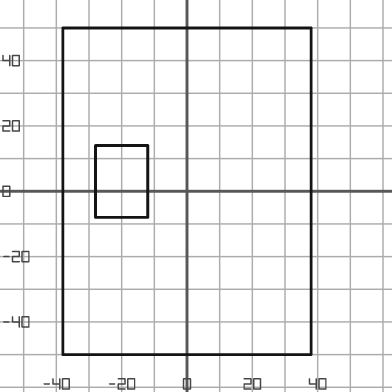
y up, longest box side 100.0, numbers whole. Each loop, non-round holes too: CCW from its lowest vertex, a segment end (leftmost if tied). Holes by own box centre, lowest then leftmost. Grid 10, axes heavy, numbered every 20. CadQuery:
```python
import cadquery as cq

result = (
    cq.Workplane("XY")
    .moveTo(-38.0, -50.0)
    .lineTo(38.0, -50.0)
    .lineTo(38.0, 50.0)
    .lineTo(-38.0, 50.0)
    .close()
    .moveTo(-28.0, -8.0)
    .lineTo(-12.0, -8.0)
    .lineTo(-12.0, 14.0)
    .lineTo(-28.0, 14.0)
    .close()
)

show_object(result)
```